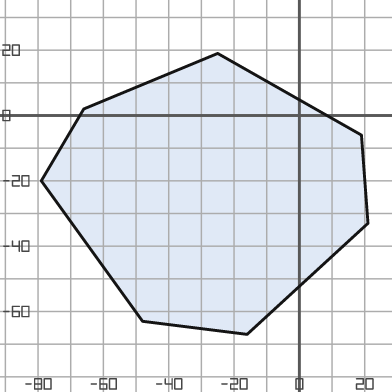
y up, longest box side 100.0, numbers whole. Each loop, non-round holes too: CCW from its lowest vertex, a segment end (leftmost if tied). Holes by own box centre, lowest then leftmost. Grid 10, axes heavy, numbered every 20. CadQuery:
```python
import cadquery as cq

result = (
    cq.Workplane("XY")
    .moveTo(-16.0, -67.0)
    .lineTo(21.0, -33.0)
    .lineTo(19.0, -6.0)
    .lineTo(-25.0, 19.0)
    .lineTo(-66.0, 2.0)
    .lineTo(-79.0, -20.0)
    .lineTo(-48.0, -63.0)
    .close()
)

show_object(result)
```